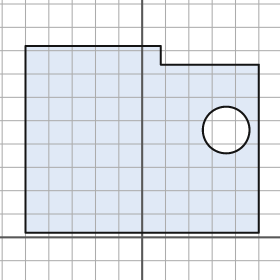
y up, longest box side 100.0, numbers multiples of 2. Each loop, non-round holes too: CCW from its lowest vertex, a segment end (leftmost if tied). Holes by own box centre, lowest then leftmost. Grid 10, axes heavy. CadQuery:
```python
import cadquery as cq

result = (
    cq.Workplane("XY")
    .moveTo(-50.0, 2.0)
    .lineTo(50.0, 2.0)
    .lineTo(50.0, 74.0)
    .lineTo(8.0, 74.0)
    .lineTo(8.0, 82.0)
    .lineTo(-50.0, 82.0)
    .close()
    .moveTo(36.0, 46.0)
    .circle(10.0)
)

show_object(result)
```